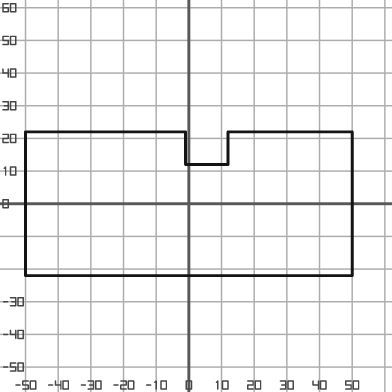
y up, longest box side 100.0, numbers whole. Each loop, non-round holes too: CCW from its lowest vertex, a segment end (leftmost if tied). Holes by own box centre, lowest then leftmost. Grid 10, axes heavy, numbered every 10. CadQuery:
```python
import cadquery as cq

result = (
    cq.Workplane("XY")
    .moveTo(-50.0, -22.0)
    .lineTo(50.0, -22.0)
    .lineTo(50.0, 22.0)
    .lineTo(12.0, 22.0)
    .lineTo(12.0, 12.0)
    .lineTo(-1.0, 12.0)
    .lineTo(-1.0, 22.0)
    .lineTo(-50.0, 22.0)
    .close()
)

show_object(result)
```